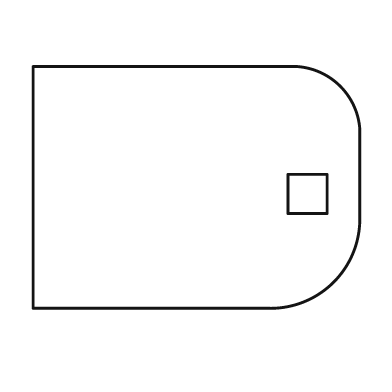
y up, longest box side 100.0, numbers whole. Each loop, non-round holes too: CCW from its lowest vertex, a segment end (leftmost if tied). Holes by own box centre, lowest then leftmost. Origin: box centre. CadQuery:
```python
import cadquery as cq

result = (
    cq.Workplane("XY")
    .moveTo(-50.0, -37.0)
    .lineTo(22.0, -37.0)
    .threePointArc((42.0, -29.0), (50.0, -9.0))
    .lineTo(50.0, 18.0)
    .threePointArc((44.0, 31.0), (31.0, 37.0))
    .lineTo(-50.0, 37.0)
    .close()
    .moveTo(28.0, -8.0)
    .lineTo(40.0, -8.0)
    .lineTo(40.0, 4.0)
    .lineTo(28.0, 4.0)
    .close()
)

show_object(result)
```